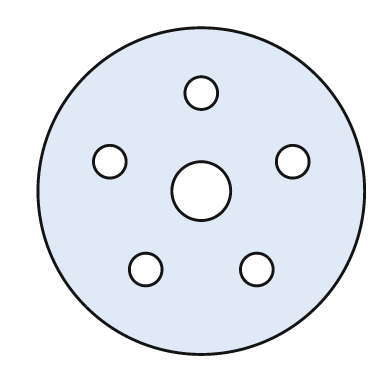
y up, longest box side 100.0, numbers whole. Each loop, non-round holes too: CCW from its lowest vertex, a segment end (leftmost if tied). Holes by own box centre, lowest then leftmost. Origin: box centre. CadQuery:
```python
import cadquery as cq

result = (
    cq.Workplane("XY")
    .moveTo(0.0, 0.0)
    .circle(50.0)
    .moveTo(-17.0, -24.0)
    .circle(5.0)
    .moveTo(17.0, -24.0)
    .circle(5.0)
    .moveTo(0.0, 0.0)
    .circle(9.0)
    .moveTo(-28.0, 9.0)
    .circle(5.0)
    .moveTo(28.0, 9.0)
    .circle(5.0)
    .moveTo(0.0, 30.0)
    .circle(5.0)
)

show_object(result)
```